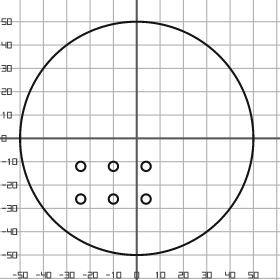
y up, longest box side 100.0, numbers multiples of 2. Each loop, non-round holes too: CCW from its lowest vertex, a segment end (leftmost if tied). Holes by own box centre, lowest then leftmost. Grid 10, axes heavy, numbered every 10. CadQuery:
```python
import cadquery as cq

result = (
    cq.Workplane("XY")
    .moveTo(0.0, 0.0)
    .circle(50.0)
    .moveTo(-24.0, -26.0)
    .circle(2.0)
    .moveTo(-10.0, -26.0)
    .circle(2.0)
    .moveTo(4.0, -26.0)
    .circle(2.0)
    .moveTo(-24.0, -12.0)
    .circle(2.0)
    .moveTo(-10.0, -12.0)
    .circle(2.0)
    .moveTo(4.0, -12.0)
    .circle(2.0)
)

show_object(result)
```